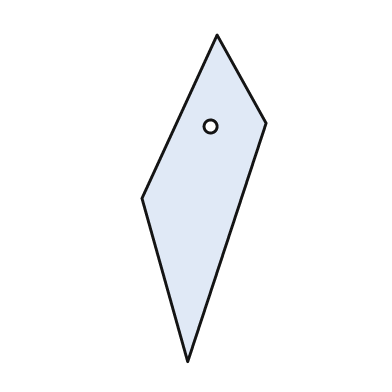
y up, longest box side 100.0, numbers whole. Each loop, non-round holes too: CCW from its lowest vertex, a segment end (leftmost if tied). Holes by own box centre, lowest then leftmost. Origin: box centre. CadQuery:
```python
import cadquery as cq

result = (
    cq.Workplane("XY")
    .moveTo(-5.0, -50.0)
    .lineTo(19.0, 23.0)
    .lineTo(4.0, 50.0)
    .lineTo(-19.0, 0.0)
    .close()
    .moveTo(2.0, 22.0)
    .circle(2.0)
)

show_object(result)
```